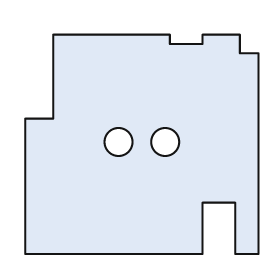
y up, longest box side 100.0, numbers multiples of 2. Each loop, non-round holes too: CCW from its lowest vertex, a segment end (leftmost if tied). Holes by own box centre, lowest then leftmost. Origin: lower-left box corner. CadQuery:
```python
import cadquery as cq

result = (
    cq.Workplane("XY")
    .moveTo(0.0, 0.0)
    .lineTo(76.0, 0.0)
    .lineTo(76.0, 22.0)
    .lineTo(90.0, 22.0)
    .lineTo(90.0, 0.0)
    .lineTo(100.0, 0.0)
    .lineTo(100.0, 86.0)
    .lineTo(92.0, 86.0)
    .lineTo(92.0, 94.0)
    .lineTo(76.0, 94.0)
    .lineTo(76.0, 90.0)
    .lineTo(62.0, 90.0)
    .lineTo(62.0, 94.0)
    .lineTo(12.0, 94.0)
    .lineTo(12.0, 58.0)
    .lineTo(0.0, 58.0)
    .close()
    .moveTo(40.0, 48.0)
    .circle(6.0)
    .moveTo(60.0, 48.0)
    .circle(6.0)
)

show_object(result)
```